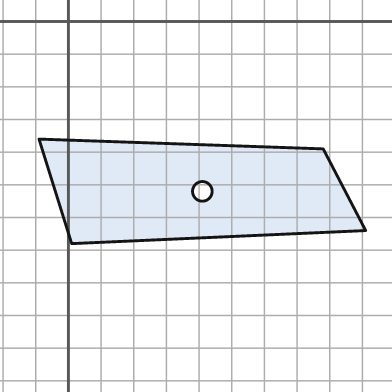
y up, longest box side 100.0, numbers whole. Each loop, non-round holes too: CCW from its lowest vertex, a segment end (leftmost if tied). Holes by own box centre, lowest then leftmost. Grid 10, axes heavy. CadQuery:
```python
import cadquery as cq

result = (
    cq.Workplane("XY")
    .moveTo(1.0, -68.0)
    .lineTo(91.0, -64.0)
    .lineTo(78.0, -39.0)
    .lineTo(-9.0, -36.0)
    .close()
    .moveTo(41.0, -52.0)
    .circle(3.0)
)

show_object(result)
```